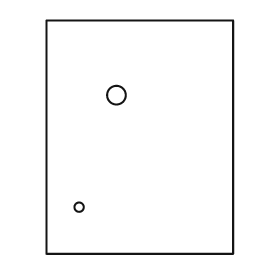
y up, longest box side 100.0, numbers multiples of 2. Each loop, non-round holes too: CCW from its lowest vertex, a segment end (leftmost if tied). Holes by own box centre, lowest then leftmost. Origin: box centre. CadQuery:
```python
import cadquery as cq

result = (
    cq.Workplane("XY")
    .moveTo(-40.0, -50.0)
    .lineTo(40.0, -50.0)
    .lineTo(40.0, 50.0)
    .lineTo(-40.0, 50.0)
    .close()
    .moveTo(-26.0, -30.0)
    .circle(2.0)
    .moveTo(-10.0, 18.0)
    .circle(4.0)
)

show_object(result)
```